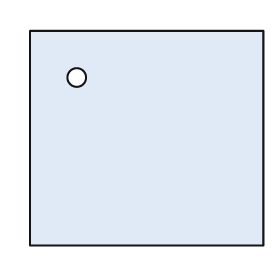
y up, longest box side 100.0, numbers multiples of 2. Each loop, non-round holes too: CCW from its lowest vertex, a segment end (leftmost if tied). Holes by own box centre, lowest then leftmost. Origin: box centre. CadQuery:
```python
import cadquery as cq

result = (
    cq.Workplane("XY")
    .moveTo(-50.0, -46.0)
    .lineTo(50.0, -46.0)
    .lineTo(50.0, 46.0)
    .lineTo(-50.0, 46.0)
    .close()
    .moveTo(-30.0, 26.0)
    .circle(4.0)
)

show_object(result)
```